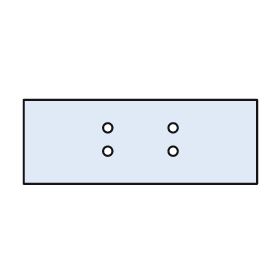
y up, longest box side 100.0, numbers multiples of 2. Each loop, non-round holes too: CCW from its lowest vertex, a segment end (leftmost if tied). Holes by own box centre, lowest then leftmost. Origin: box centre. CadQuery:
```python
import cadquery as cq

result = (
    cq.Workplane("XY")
    .moveTo(-50.0, -18.0)
    .lineTo(50.0, -18.0)
    .lineTo(50.0, 18.0)
    .lineTo(-50.0, 18.0)
    .close()
    .moveTo(-14.0, -4.0)
    .circle(2.0)
    .moveTo(14.0, -4.0)
    .circle(2.0)
    .moveTo(-14.0, 6.0)
    .circle(2.0)
    .moveTo(14.0, 6.0)
    .circle(2.0)
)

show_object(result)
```